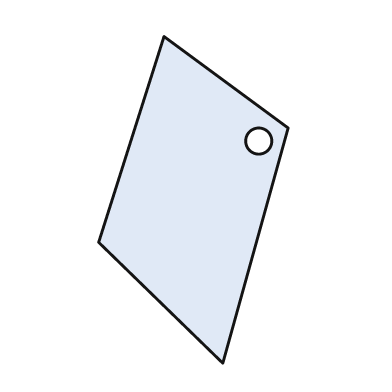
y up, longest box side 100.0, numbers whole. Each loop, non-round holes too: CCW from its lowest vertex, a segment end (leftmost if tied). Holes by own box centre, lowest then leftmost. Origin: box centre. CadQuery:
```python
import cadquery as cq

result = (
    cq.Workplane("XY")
    .moveTo(9.0, -50.0)
    .lineTo(29.0, 22.0)
    .lineTo(-9.0, 50.0)
    .lineTo(-29.0, -13.0)
    .close()
    .moveTo(20.0, 18.0)
    .circle(4.0)
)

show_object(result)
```